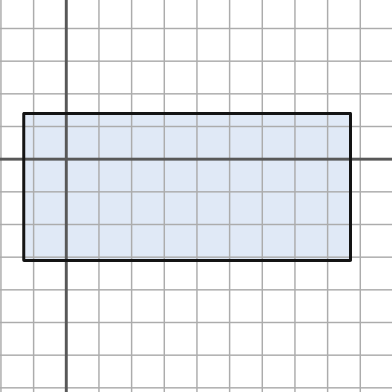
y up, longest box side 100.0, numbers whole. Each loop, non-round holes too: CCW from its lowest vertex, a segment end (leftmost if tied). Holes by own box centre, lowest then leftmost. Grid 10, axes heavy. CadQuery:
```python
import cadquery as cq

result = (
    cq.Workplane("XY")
    .moveTo(-13.0, -31.0)
    .lineTo(87.0, -31.0)
    .lineTo(87.0, 14.0)
    .lineTo(-13.0, 14.0)
    .close()
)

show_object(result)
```